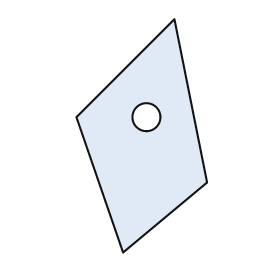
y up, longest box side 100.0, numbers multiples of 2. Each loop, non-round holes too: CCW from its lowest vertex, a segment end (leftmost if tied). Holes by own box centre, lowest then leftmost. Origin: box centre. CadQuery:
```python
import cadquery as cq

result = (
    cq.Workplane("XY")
    .moveTo(-8.0, -50.0)
    .lineTo(28.0, -20.0)
    .lineTo(14.0, 50.0)
    .lineTo(-28.0, 8.0)
    .close()
    .moveTo(2.0, 8.0)
    .circle(6.0)
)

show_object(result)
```